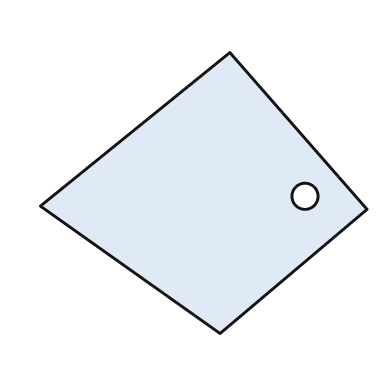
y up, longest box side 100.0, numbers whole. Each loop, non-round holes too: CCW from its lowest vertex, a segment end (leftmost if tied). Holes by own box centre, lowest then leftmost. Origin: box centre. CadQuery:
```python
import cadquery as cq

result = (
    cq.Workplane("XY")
    .moveTo(5.0, -43.0)
    .lineTo(50.0, -5.0)
    .lineTo(8.0, 43.0)
    .lineTo(-50.0, -4.0)
    .close()
    .moveTo(31.0, -1.0)
    .circle(4.0)
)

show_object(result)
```